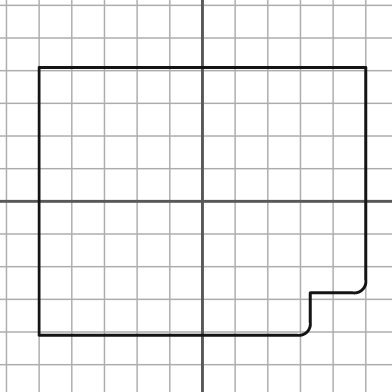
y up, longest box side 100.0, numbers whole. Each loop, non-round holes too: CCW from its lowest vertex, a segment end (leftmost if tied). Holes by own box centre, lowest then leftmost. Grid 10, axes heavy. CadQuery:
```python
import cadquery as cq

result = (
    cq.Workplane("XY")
    .moveTo(-50.0, -41.0)
    .lineTo(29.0, -41.0)
    .threePointArc((32.0, -40.0), (33.0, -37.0))
    .lineTo(33.0, -28.0)
    .lineTo(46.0, -28.0)
    .threePointArc((49.0, -27.0), (50.0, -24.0))
    .lineTo(50.0, 41.0)
    .lineTo(-50.0, 41.0)
    .close()
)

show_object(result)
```